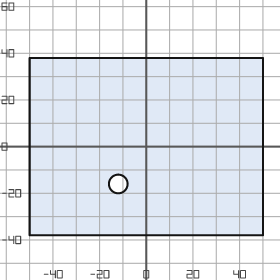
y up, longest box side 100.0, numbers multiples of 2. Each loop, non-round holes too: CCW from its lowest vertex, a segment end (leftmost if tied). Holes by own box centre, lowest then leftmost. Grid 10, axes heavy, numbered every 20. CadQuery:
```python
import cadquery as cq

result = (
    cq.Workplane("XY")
    .moveTo(-50.0, -38.0)
    .lineTo(50.0, -38.0)
    .lineTo(50.0, 38.0)
    .lineTo(-50.0, 38.0)
    .close()
    .moveTo(-12.0, -16.0)
    .circle(4.0)
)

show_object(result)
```